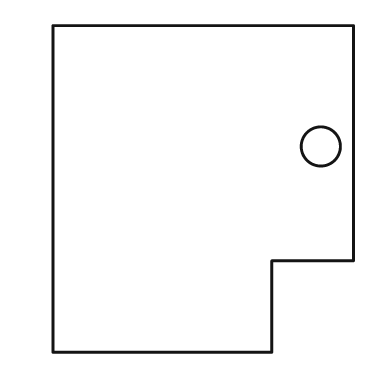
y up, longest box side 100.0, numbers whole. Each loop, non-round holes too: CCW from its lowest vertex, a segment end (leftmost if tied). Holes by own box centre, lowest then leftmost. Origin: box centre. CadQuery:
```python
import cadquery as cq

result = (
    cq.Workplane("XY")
    .moveTo(-46.0, -50.0)
    .lineTo(21.0, -50.0)
    .lineTo(21.0, -22.0)
    .lineTo(46.0, -22.0)
    .lineTo(46.0, 50.0)
    .lineTo(-46.0, 50.0)
    .close()
    .moveTo(36.0, 13.0)
    .circle(6.0)
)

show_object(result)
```